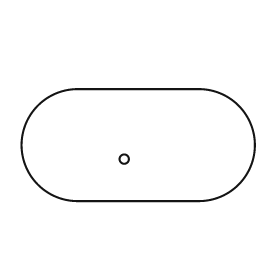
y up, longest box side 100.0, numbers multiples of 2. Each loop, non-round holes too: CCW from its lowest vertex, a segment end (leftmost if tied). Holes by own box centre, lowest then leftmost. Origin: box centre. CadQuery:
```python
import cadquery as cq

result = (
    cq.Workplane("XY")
    .moveTo(-26.0, -24.0)
    .lineTo(26.0, -24.0)
    .threePointArc((50.0, 0.0), (26.0, 24.0))
    .lineTo(-26.0, 24.0)
    .threePointArc((-50.0, 0.0), (-26.0, -24.0))
    .close()
    .moveTo(-6.0, -6.0)
    .circle(2.0)
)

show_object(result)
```